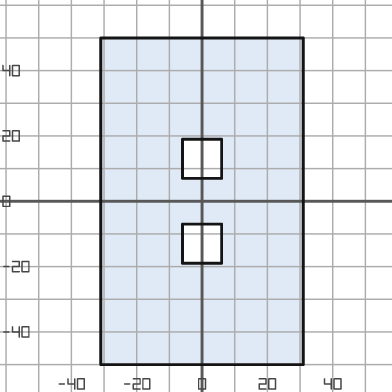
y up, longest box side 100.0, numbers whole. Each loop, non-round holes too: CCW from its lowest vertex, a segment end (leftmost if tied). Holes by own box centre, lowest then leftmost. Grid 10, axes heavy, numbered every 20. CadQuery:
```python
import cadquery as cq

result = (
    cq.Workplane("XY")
    .moveTo(-31.0, -50.0)
    .lineTo(31.0, -50.0)
    .lineTo(31.0, 50.0)
    .lineTo(-31.0, 50.0)
    .close()
    .moveTo(-6.0, -19.0)
    .lineTo(6.0, -19.0)
    .lineTo(6.0, -7.0)
    .lineTo(-6.0, -7.0)
    .close()
    .moveTo(-6.0, 7.0)
    .lineTo(6.0, 7.0)
    .lineTo(6.0, 19.0)
    .lineTo(-6.0, 19.0)
    .close()
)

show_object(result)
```